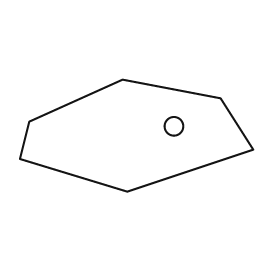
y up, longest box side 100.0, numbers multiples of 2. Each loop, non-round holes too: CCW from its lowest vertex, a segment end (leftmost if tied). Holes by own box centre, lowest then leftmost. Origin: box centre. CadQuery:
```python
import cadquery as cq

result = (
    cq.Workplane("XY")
    .moveTo(-4.0, -24.0)
    .lineTo(50.0, -6.0)
    .lineTo(36.0, 16.0)
    .lineTo(-6.0, 24.0)
    .lineTo(-46.0, 6.0)
    .lineTo(-50.0, -10.0)
    .close()
    .moveTo(16.0, 4.0)
    .circle(4.0)
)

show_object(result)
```